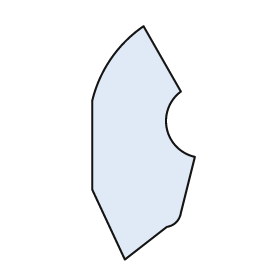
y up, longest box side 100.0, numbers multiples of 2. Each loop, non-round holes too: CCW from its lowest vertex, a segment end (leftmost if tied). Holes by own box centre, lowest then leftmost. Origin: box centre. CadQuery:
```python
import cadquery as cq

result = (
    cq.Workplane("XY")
    .moveTo(-8.0, -50.0)
    .lineTo(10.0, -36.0)
    .threePointArc((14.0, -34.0), (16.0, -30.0))
    .lineTo(22.0, -6.0)
    .threePointArc((10.0, 6.0), (16.0, 22.0))
    .lineTo(0.0, 50.0)
    .threePointArc((-14.0, 36.0), (-22.0, 18.0))
    .lineTo(-22.0, -20.0)
    .close()
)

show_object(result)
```